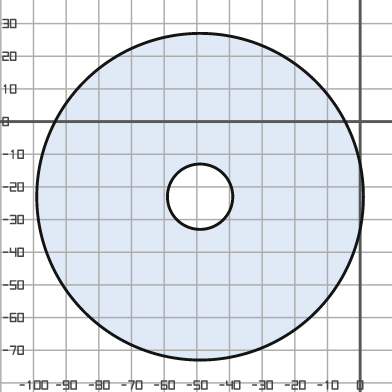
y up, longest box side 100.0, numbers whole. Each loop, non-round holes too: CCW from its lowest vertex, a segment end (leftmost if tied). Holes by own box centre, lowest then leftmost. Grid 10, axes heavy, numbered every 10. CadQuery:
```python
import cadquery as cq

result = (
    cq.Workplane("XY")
    .moveTo(-49.0, -23.0)
    .circle(50.0)
    .moveTo(-49.0, -23.0)
    .circle(10.0)
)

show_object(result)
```